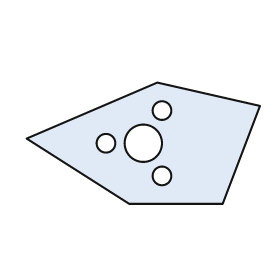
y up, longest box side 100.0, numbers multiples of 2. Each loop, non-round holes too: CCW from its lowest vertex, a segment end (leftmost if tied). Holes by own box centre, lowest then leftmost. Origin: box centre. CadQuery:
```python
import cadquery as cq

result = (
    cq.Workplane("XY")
    .moveTo(-6.0, -26.0)
    .lineTo(34.0, -26.0)
    .lineTo(50.0, 16.0)
    .lineTo(6.0, 26.0)
    .lineTo(-50.0, 2.0)
    .close()
    .moveTo(8.0, -14.0)
    .circle(4.0)
    .moveTo(-16.0, 0.0)
    .circle(4.0)
    .moveTo(0.0, 0.0)
    .circle(8.0)
    .moveTo(8.0, 14.0)
    .circle(4.0)
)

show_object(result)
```